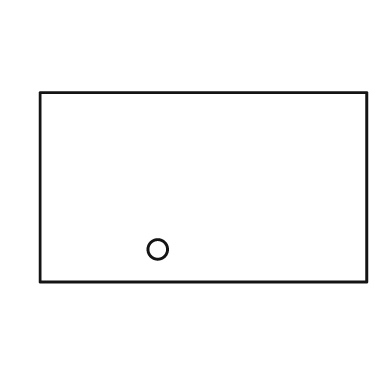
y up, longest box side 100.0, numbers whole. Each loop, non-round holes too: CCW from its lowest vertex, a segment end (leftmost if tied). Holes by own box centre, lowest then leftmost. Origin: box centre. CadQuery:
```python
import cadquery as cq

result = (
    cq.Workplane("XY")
    .moveTo(-50.0, -29.0)
    .lineTo(50.0, -29.0)
    .lineTo(50.0, 29.0)
    .lineTo(-50.0, 29.0)
    .close()
    .moveTo(-14.0, -19.0)
    .circle(3.0)
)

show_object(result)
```